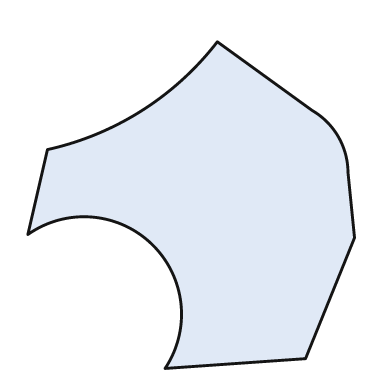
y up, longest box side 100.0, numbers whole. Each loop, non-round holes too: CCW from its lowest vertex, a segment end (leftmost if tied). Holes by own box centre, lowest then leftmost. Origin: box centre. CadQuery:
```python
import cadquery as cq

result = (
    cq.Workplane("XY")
    .moveTo(-8.0, -50.0)
    .lineTo(35.0, -47.0)
    .lineTo(50.0, -10.0)
    .lineTo(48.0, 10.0)
    .threePointArc((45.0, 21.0), (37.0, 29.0))
    .lineTo(8.0, 50.0)
    .threePointArc((-15.0, 29.0), (-44.0, 17.0))
    .lineTo(-50.0, -9.0)
    .threePointArc((-12.0, -12.0), (-8.0, -50.0))
    .close()
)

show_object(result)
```